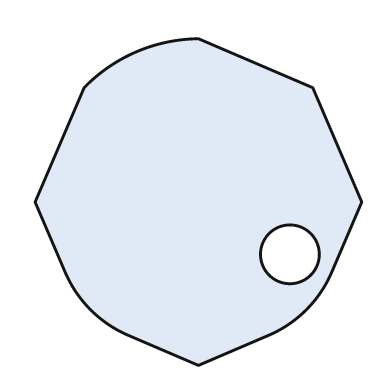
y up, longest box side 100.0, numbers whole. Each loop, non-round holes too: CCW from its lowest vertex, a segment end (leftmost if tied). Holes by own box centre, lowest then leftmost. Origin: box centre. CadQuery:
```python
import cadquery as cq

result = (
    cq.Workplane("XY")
    .moveTo(0.0, -50.0)
    .lineTo(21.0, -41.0)
    .threePointArc((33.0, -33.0), (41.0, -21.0))
    .lineTo(50.0, 0.0)
    .lineTo(35.0, 35.0)
    .lineTo(0.0, 50.0)
    .threePointArc((-19.0, 46.0), (-35.0, 35.0))
    .lineTo(-50.0, 0.0)
    .lineTo(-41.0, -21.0)
    .threePointArc((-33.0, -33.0), (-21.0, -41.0))
    .close()
    .moveTo(28.0, -16.0)
    .circle(9.0)
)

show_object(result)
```